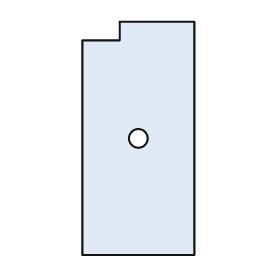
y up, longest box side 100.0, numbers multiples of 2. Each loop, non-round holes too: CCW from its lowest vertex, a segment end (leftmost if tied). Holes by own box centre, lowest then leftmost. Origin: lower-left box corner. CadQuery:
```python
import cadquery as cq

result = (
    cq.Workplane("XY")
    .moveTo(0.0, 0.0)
    .lineTo(48.0, 0.0)
    .lineTo(48.0, 100.0)
    .lineTo(16.0, 100.0)
    .lineTo(16.0, 92.0)
    .lineTo(0.0, 92.0)
    .close()
    .moveTo(24.0, 50.0)
    .circle(4.0)
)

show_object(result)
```